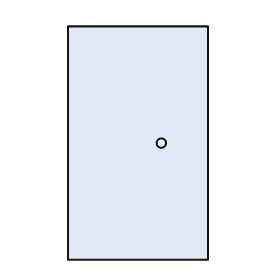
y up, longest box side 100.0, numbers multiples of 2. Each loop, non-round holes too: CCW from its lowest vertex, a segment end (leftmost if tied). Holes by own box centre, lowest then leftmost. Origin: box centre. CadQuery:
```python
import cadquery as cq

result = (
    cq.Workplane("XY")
    .moveTo(-30.0, -50.0)
    .lineTo(30.0, -50.0)
    .lineTo(30.0, 50.0)
    .lineTo(-30.0, 50.0)
    .close()
    .moveTo(10.0, 0.0)
    .circle(2.0)
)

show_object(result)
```